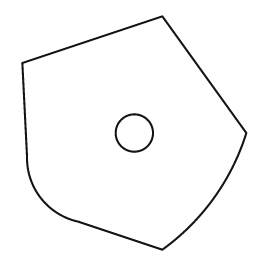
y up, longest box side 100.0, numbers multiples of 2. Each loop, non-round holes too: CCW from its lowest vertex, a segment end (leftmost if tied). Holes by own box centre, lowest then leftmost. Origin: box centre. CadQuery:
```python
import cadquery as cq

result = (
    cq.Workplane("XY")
    .moveTo(12.0, -50.0)
    .threePointArc((34.0, -28.0), (48.0, 0.0))
    .lineTo(12.0, 50.0)
    .lineTo(-48.0, 30.0)
    .lineTo(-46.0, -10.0)
    .threePointArc((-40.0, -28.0), (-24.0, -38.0))
    .close()
    .moveTo(0.0, 0.0)
    .circle(8.0)
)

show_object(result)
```